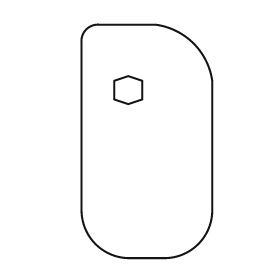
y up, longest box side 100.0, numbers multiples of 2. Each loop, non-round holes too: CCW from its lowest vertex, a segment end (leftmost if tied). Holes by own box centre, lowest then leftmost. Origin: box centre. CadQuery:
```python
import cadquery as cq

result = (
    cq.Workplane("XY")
    .moveTo(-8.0, -50.0)
    .lineTo(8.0, -50.0)
    .threePointArc((22.0, -44.0), (28.0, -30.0))
    .lineTo(28.0, 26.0)
    .threePointArc((20.0, 42.0), (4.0, 50.0))
    .lineTo(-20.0, 50.0)
    .threePointArc((-26.0, 48.0), (-28.0, 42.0))
    .lineTo(-28.0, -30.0)
    .threePointArc((-22.0, -44.0), (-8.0, -50.0))
    .close()
    .moveTo(-8.0, 16.0)
    .lineTo(-2.0, 18.0)
    .lineTo(-2.0, 26.0)
    .lineTo(-8.0, 28.0)
    .lineTo(-14.0, 26.0)
    .lineTo(-14.0, 18.0)
    .close()
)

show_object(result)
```